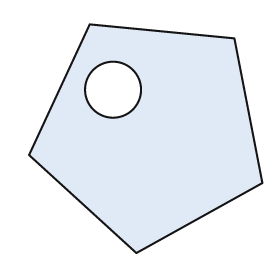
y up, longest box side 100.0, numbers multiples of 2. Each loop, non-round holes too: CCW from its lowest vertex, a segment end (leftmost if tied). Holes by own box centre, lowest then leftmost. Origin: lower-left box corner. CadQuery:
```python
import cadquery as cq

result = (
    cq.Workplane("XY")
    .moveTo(46.0, 0.0)
    .lineTo(100.0, 30.0)
    .lineTo(88.0, 92.0)
    .lineTo(26.0, 98.0)
    .lineTo(0.0, 42.0)
    .close()
    .moveTo(36.0, 70.0)
    .circle(12.0)
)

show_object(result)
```